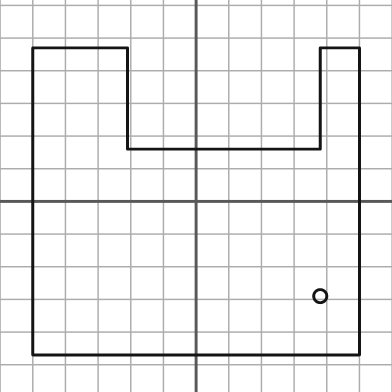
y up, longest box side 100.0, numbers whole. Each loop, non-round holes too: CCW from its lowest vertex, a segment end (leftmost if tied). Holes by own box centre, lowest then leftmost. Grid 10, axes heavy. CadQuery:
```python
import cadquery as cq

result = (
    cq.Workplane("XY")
    .moveTo(-50.0, -47.0)
    .lineTo(50.0, -47.0)
    .lineTo(50.0, 47.0)
    .lineTo(38.0, 47.0)
    .lineTo(38.0, 16.0)
    .lineTo(-21.0, 16.0)
    .lineTo(-21.0, 47.0)
    .lineTo(-50.0, 47.0)
    .close()
    .moveTo(38.0, -29.0)
    .circle(2.0)
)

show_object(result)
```